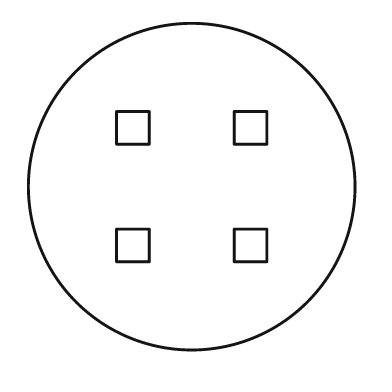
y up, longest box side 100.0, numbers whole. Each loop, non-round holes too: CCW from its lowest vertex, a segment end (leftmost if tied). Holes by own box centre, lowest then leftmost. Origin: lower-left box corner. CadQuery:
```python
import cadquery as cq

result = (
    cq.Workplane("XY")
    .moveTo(50.0, 50.0)
    .circle(50.0)
    .moveTo(27.0, 27.0)
    .lineTo(37.0, 27.0)
    .lineTo(37.0, 37.0)
    .lineTo(27.0, 37.0)
    .close()
    .moveTo(63.0, 27.0)
    .lineTo(73.0, 27.0)
    .lineTo(73.0, 37.0)
    .lineTo(63.0, 37.0)
    .close()
    .moveTo(27.0, 63.0)
    .lineTo(37.0, 63.0)
    .lineTo(37.0, 73.0)
    .lineTo(27.0, 73.0)
    .close()
    .moveTo(63.0, 63.0)
    .lineTo(73.0, 63.0)
    .lineTo(73.0, 73.0)
    .lineTo(63.0, 73.0)
    .close()
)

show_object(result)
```